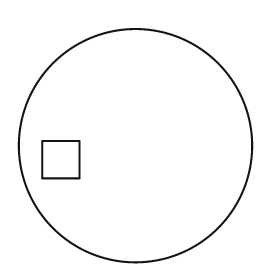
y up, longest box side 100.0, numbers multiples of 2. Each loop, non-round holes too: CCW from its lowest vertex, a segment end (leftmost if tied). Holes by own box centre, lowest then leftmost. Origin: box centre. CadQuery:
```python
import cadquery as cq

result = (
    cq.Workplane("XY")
    .moveTo(0.0, 0.0)
    .circle(50.0)
    .moveTo(-40.0, -14.0)
    .lineTo(-24.0, -14.0)
    .lineTo(-24.0, 2.0)
    .lineTo(-40.0, 2.0)
    .close()
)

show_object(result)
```